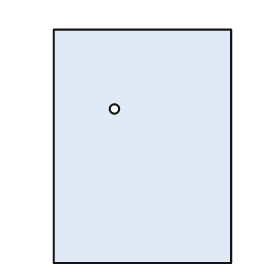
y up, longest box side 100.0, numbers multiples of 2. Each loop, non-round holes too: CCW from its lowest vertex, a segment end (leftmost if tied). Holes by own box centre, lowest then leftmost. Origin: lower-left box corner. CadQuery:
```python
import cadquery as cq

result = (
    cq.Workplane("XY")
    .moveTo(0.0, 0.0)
    .lineTo(76.0, 0.0)
    .lineTo(76.0, 100.0)
    .lineTo(0.0, 100.0)
    .close()
    .moveTo(26.0, 66.0)
    .circle(2.0)
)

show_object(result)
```